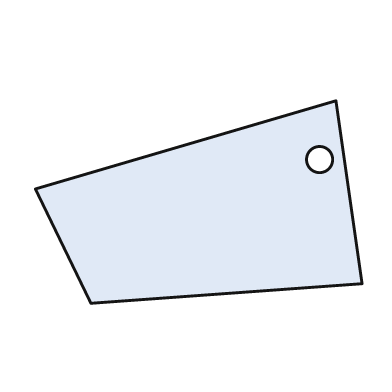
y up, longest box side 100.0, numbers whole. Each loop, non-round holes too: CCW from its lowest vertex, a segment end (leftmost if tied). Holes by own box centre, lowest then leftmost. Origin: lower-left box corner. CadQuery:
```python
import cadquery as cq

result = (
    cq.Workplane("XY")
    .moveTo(17.0, 0.0)
    .lineTo(100.0, 6.0)
    .lineTo(92.0, 62.0)
    .lineTo(0.0, 35.0)
    .close()
    .moveTo(87.0, 44.0)
    .circle(4.0)
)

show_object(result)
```